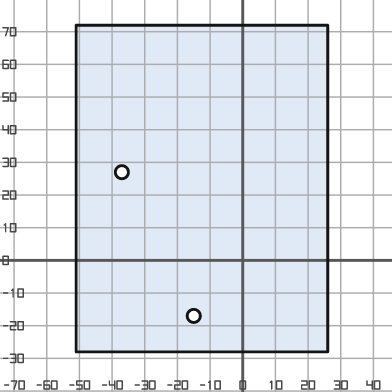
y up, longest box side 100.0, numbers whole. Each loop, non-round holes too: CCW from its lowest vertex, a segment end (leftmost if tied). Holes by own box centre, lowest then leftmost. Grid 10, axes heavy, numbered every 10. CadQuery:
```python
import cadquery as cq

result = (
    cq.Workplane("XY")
    .moveTo(-51.0, -28.0)
    .lineTo(26.0, -28.0)
    .lineTo(26.0, 72.0)
    .lineTo(-51.0, 72.0)
    .close()
    .moveTo(-15.0, -17.0)
    .circle(2.0)
    .moveTo(-37.0, 27.0)
    .circle(2.0)
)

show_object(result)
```